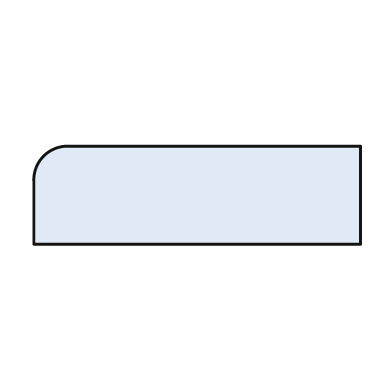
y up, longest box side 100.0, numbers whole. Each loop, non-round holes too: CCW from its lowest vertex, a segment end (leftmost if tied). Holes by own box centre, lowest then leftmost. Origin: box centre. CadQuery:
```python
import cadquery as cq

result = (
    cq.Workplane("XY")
    .moveTo(-50.0, -15.0)
    .lineTo(50.0, -15.0)
    .lineTo(50.0, 15.0)
    .lineTo(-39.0, 15.0)
    .threePointArc((-47.0, 12.0), (-50.0, 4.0))
    .close()
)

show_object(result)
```